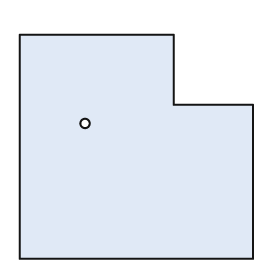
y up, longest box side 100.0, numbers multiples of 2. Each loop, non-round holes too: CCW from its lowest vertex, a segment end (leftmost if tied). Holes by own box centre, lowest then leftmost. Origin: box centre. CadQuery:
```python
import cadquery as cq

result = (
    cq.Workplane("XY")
    .moveTo(-50.0, -48.0)
    .lineTo(50.0, -48.0)
    .lineTo(50.0, 18.0)
    .lineTo(16.0, 18.0)
    .lineTo(16.0, 48.0)
    .lineTo(-50.0, 48.0)
    .close()
    .moveTo(-22.0, 10.0)
    .circle(2.0)
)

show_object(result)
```